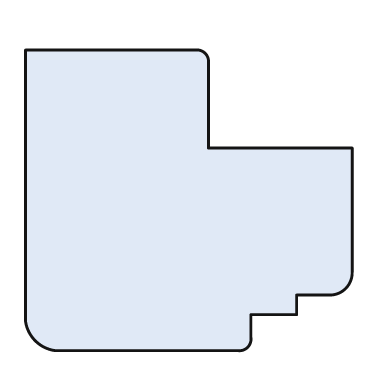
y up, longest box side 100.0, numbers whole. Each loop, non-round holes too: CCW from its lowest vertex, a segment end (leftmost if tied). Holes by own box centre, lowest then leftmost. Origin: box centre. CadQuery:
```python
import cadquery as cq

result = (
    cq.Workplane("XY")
    .moveTo(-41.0, -46.0)
    .lineTo(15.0, -46.0)
    .threePointArc((18.0, -45.0), (19.0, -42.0))
    .lineTo(19.0, -35.0)
    .lineTo(33.0, -35.0)
    .lineTo(33.0, -29.0)
    .lineTo(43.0, -29.0)
    .threePointArc((48.0, -27.0), (50.0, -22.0))
    .lineTo(50.0, 16.0)
    .lineTo(6.0, 16.0)
    .lineTo(6.0, 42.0)
    .threePointArc((5.0, 45.0), (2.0, 46.0))
    .lineTo(-50.0, 46.0)
    .lineTo(-50.0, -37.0)
    .threePointArc((-47.0, -43.0), (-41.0, -46.0))
    .close()
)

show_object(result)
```